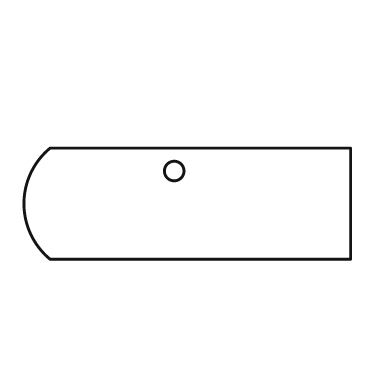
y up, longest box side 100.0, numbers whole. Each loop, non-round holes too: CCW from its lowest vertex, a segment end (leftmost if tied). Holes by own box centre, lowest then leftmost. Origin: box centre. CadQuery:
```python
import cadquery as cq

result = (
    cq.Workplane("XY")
    .moveTo(-42.0, -17.0)
    .lineTo(50.0, -17.0)
    .lineTo(50.0, 17.0)
    .lineTo(-42.0, 17.0)
    .threePointArc((-50.0, 0.0), (-42.0, -17.0))
    .close()
    .moveTo(-4.0, 10.0)
    .circle(3.0)
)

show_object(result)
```